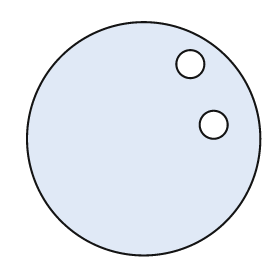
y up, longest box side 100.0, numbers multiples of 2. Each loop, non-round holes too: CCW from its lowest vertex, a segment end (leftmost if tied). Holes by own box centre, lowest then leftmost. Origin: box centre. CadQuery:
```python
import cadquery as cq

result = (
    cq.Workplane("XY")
    .moveTo(0.0, 0.0)
    .circle(50.0)
    .moveTo(30.0, 6.0)
    .circle(6.0)
    .moveTo(20.0, 32.0)
    .circle(6.0)
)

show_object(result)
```